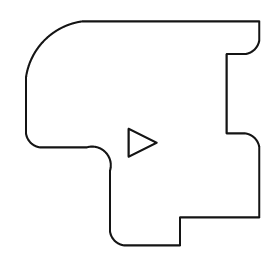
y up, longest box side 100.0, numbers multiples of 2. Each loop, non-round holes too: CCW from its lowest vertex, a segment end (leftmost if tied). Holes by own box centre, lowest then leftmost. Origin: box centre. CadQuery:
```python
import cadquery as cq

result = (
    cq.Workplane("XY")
    .moveTo(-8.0, -48.0)
    .lineTo(16.0, -48.0)
    .lineTo(16.0, -36.0)
    .lineTo(50.0, -36.0)
    .lineTo(50.0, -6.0)
    .threePointArc((48.0, -2.0), (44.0, 0.0))
    .lineTo(36.0, 0.0)
    .lineTo(36.0, 34.0)
    .lineTo(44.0, 34.0)
    .threePointArc((48.0, 36.0), (50.0, 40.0))
    .lineTo(50.0, 48.0)
    .lineTo(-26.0, 48.0)
    .threePointArc((-42.0, 40.0), (-50.0, 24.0))
    .lineTo(-50.0, 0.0)
    .threePointArc((-48.0, -4.0), (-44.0, -6.0))
    .lineTo(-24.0, -6.0)
    .threePointArc((-16.0, -8.0), (-14.0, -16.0))
    .lineTo(-14.0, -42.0)
    .threePointArc((-12.0, -46.0), (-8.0, -48.0))
    .close()
    .moveTo(-6.0, -10.0)
    .lineTo(6.0, -4.0)
    .lineTo(-6.0, 2.0)
    .close()
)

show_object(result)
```